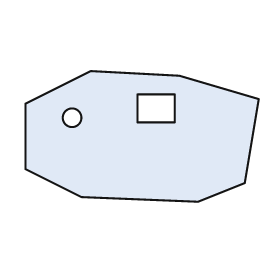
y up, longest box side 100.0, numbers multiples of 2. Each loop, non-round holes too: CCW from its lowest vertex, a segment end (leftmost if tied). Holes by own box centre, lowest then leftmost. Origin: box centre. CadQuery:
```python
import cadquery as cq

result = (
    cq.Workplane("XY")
    .moveTo(24.0, -28.0)
    .lineTo(44.0, -20.0)
    .lineTo(50.0, 16.0)
    .lineTo(16.0, 26.0)
    .lineTo(-22.0, 28.0)
    .lineTo(-50.0, 14.0)
    .lineTo(-50.0, -14.0)
    .lineTo(-26.0, -26.0)
    .close()
    .moveTo(-30.0, 8.0)
    .circle(4.0)
    .moveTo(-2.0, 6.0)
    .lineTo(14.0, 6.0)
    .lineTo(14.0, 18.0)
    .lineTo(-2.0, 18.0)
    .close()
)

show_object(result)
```